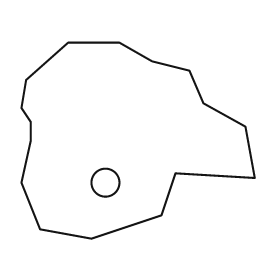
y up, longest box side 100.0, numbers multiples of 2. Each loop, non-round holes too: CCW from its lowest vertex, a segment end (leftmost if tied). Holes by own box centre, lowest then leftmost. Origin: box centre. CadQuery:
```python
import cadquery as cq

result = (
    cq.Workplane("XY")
    .moveTo(-20.0, -42.0)
    .lineTo(10.0, -32.0)
    .lineTo(16.0, -14.0)
    .lineTo(50.0, -16.0)
    .lineTo(46.0, 6.0)
    .lineTo(28.0, 16.0)
    .lineTo(22.0, 30.0)
    .lineTo(6.0, 34.0)
    .lineTo(-8.0, 42.0)
    .lineTo(-30.0, 42.0)
    .lineTo(-48.0, 26.0)
    .lineTo(-50.0, 14.0)
    .lineTo(-46.0, 8.0)
    .lineTo(-46.0, 0.0)
    .lineTo(-50.0, -18.0)
    .lineTo(-42.0, -38.0)
    .close()
    .moveTo(-14.0, -18.0)
    .circle(6.0)
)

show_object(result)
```